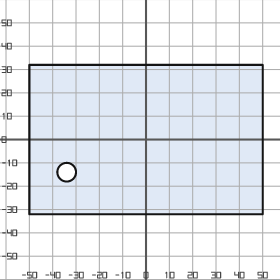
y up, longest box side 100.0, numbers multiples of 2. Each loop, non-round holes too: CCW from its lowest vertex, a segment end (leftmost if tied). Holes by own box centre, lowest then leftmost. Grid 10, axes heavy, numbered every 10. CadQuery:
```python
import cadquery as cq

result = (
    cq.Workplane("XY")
    .moveTo(-50.0, -32.0)
    .lineTo(50.0, -32.0)
    .lineTo(50.0, 32.0)
    .lineTo(-50.0, 32.0)
    .close()
    .moveTo(-34.0, -14.0)
    .circle(4.0)
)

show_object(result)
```